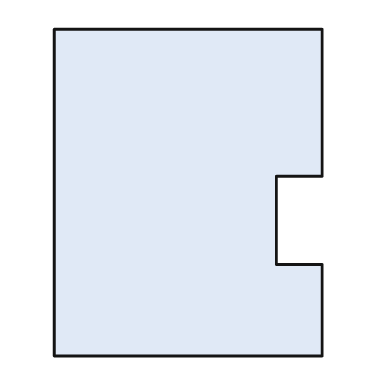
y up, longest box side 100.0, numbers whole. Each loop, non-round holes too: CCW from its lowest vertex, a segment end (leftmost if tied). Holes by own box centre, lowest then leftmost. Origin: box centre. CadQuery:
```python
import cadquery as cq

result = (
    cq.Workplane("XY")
    .moveTo(-41.0, -50.0)
    .lineTo(41.0, -50.0)
    .lineTo(41.0, -22.0)
    .lineTo(27.0, -22.0)
    .lineTo(27.0, 5.0)
    .lineTo(41.0, 5.0)
    .lineTo(41.0, 50.0)
    .lineTo(-41.0, 50.0)
    .close()
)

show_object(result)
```